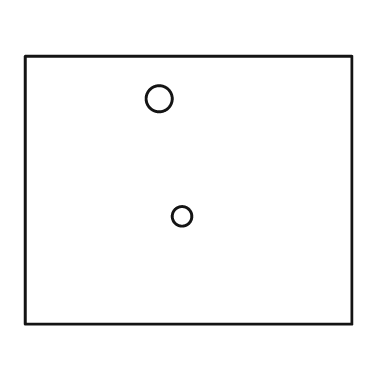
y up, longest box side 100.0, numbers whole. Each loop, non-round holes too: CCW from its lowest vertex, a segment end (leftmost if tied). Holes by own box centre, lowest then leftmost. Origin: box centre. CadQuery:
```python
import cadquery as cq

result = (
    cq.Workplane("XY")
    .moveTo(-50.0, -41.0)
    .lineTo(50.0, -41.0)
    .lineTo(50.0, 41.0)
    .lineTo(-50.0, 41.0)
    .close()
    .moveTo(-2.0, -8.0)
    .circle(3.0)
    .moveTo(-9.0, 28.0)
    .circle(4.0)
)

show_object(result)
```